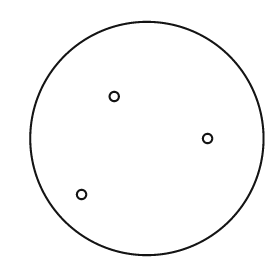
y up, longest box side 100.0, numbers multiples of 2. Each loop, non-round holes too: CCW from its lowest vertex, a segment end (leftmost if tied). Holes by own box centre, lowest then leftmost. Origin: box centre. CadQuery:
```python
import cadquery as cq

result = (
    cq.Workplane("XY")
    .moveTo(0.0, 0.0)
    .circle(50.0)
    .moveTo(-28.0, -24.0)
    .circle(2.0)
    .moveTo(26.0, 0.0)
    .circle(2.0)
    .moveTo(-14.0, 18.0)
    .circle(2.0)
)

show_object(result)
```